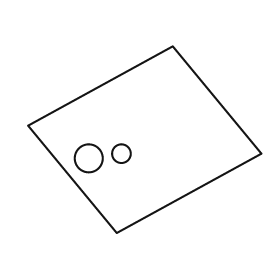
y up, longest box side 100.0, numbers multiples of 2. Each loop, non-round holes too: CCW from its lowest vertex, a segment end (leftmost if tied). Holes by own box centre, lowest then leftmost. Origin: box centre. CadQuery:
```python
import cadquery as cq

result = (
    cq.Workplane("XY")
    .moveTo(-12.0, -40.0)
    .lineTo(50.0, -6.0)
    .lineTo(12.0, 40.0)
    .lineTo(-50.0, 6.0)
    .close()
    .moveTo(-24.0, -8.0)
    .circle(6.0)
    .moveTo(-10.0, -6.0)
    .circle(4.0)
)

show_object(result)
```